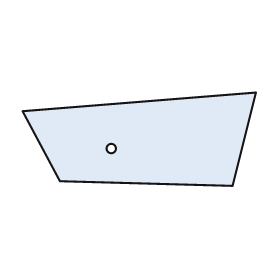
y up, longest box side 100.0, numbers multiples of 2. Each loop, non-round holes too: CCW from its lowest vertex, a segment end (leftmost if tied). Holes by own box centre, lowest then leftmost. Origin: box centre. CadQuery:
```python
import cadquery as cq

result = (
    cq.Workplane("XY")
    .moveTo(40.0, -20.0)
    .lineTo(50.0, 20.0)
    .lineTo(-50.0, 12.0)
    .lineTo(-34.0, -18.0)
    .close()
    .moveTo(-12.0, -4.0)
    .circle(2.0)
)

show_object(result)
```